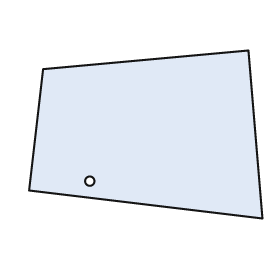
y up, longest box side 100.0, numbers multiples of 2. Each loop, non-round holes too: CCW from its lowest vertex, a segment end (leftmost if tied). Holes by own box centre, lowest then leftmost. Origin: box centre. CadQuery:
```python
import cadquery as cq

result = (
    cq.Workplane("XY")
    .moveTo(50.0, -36.0)
    .lineTo(44.0, 36.0)
    .lineTo(-44.0, 28.0)
    .lineTo(-50.0, -24.0)
    .close()
    .moveTo(-24.0, -20.0)
    .circle(2.0)
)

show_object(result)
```